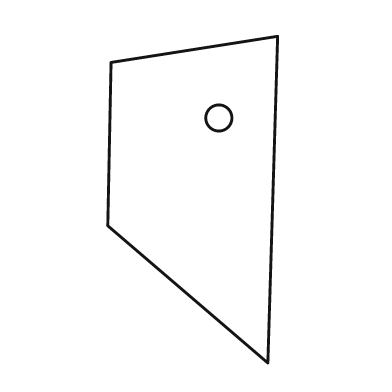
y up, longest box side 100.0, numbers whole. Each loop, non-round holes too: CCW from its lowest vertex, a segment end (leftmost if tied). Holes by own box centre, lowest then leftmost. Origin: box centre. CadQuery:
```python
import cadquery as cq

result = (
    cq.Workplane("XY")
    .moveTo(23.0, -50.0)
    .lineTo(26.0, 50.0)
    .lineTo(-25.0, 42.0)
    .lineTo(-26.0, -8.0)
    .close()
    .moveTo(8.0, 25.0)
    .circle(4.0)
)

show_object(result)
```